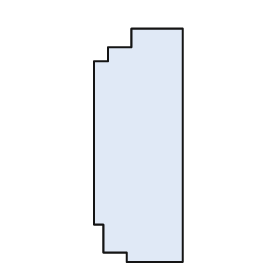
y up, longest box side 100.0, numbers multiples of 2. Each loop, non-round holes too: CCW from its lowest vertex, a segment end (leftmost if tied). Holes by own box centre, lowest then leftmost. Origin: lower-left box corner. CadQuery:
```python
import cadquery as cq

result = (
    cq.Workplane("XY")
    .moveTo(14.0, 0.0)
    .lineTo(38.0, 0.0)
    .lineTo(38.0, 100.0)
    .lineTo(16.0, 100.0)
    .lineTo(16.0, 92.0)
    .lineTo(6.0, 92.0)
    .lineTo(6.0, 86.0)
    .lineTo(0.0, 86.0)
    .lineTo(0.0, 16.0)
    .lineTo(4.0, 16.0)
    .lineTo(4.0, 4.0)
    .lineTo(14.0, 4.0)
    .close()
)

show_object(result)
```